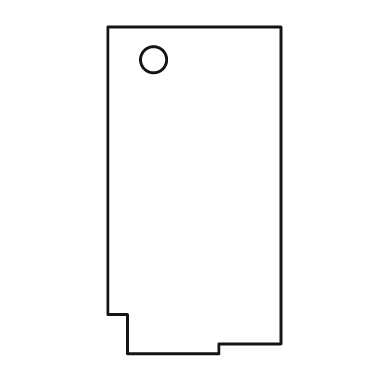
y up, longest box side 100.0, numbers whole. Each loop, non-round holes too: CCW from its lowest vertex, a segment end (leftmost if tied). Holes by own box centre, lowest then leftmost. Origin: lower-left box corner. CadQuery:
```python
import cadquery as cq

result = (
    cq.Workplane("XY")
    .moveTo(6.0, 0.0)
    .lineTo(34.0, 0.0)
    .lineTo(34.0, 3.0)
    .lineTo(53.0, 3.0)
    .lineTo(53.0, 100.0)
    .lineTo(0.0, 100.0)
    .lineTo(0.0, 12.0)
    .lineTo(6.0, 12.0)
    .close()
    .moveTo(14.0, 90.0)
    .circle(4.0)
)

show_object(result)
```